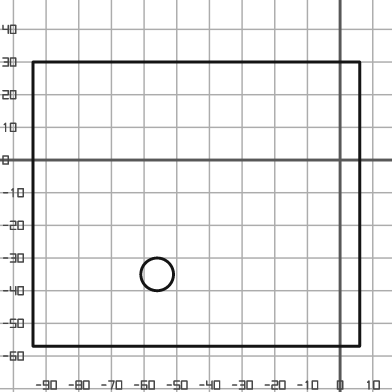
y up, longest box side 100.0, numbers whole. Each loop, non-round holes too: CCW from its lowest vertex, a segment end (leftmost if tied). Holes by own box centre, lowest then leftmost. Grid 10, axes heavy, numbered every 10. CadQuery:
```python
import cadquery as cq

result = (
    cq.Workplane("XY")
    .moveTo(-94.0, -57.0)
    .lineTo(6.0, -57.0)
    .lineTo(6.0, 30.0)
    .lineTo(-94.0, 30.0)
    .close()
    .moveTo(-56.0, -35.0)
    .circle(5.0)
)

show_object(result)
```